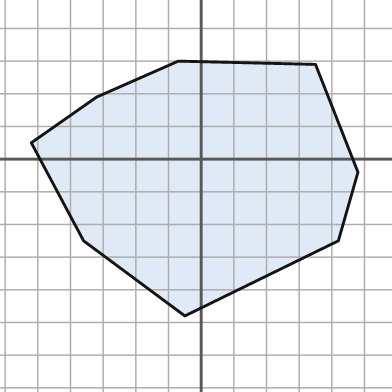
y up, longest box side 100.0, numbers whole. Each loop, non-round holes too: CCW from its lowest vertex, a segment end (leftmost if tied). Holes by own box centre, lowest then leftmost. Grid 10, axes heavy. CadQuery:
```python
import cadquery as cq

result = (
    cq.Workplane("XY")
    .moveTo(-5.0, -48.0)
    .lineTo(42.0, -25.0)
    .lineTo(48.0, -4.0)
    .lineTo(35.0, 29.0)
    .lineTo(-7.0, 30.0)
    .lineTo(-32.0, 19.0)
    .lineTo(-52.0, 5.0)
    .lineTo(-36.0, -25.0)
    .close()
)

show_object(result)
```